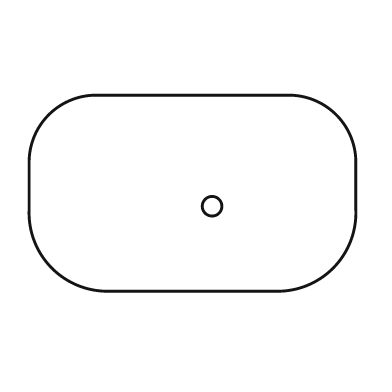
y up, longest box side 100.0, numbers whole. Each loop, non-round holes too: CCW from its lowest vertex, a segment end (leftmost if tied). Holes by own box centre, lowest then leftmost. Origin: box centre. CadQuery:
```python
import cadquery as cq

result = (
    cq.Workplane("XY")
    .moveTo(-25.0, -30.0)
    .lineTo(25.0, -30.0)
    .threePointArc((43.0, -23.0), (50.0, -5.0))
    .lineTo(50.0, 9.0)
    .threePointArc((44.0, 24.0), (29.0, 30.0))
    .lineTo(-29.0, 30.0)
    .threePointArc((-44.0, 24.0), (-50.0, 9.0))
    .lineTo(-50.0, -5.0)
    .threePointArc((-43.0, -23.0), (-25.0, -30.0))
    .close()
    .moveTo(6.0, -4.0)
    .circle(3.0)
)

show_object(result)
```